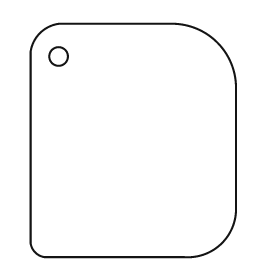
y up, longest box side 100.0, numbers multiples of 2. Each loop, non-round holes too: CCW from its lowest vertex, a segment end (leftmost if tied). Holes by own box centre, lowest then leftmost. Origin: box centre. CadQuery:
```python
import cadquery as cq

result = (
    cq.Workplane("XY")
    .moveTo(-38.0, -50.0)
    .lineTo(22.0, -50.0)
    .threePointArc((38.0, -44.0), (44.0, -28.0))
    .lineTo(44.0, 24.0)
    .threePointArc((36.0, 42.0), (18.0, 50.0))
    .lineTo(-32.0, 50.0)
    .threePointArc((-40.0, 46.0), (-44.0, 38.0))
    .lineTo(-44.0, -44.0)
    .threePointArc((-42.0, -48.0), (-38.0, -50.0))
    .close()
    .moveTo(-32.0, 36.0)
    .circle(4.0)
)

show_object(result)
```